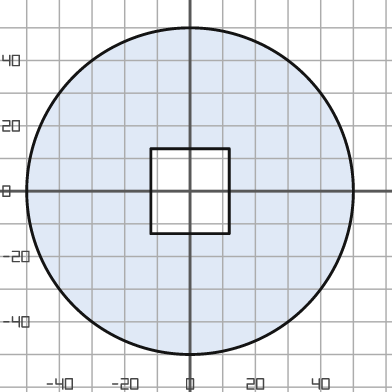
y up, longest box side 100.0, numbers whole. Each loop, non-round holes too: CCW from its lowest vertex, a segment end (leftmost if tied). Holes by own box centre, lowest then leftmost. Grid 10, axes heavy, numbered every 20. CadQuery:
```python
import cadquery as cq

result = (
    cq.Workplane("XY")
    .moveTo(0.0, 0.0)
    .circle(50.0)
    .moveTo(-12.0, -13.0)
    .lineTo(12.0, -13.0)
    .lineTo(12.0, 13.0)
    .lineTo(-12.0, 13.0)
    .close()
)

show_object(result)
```